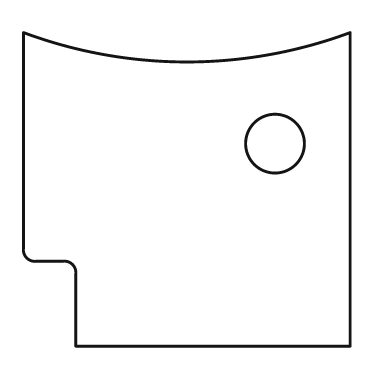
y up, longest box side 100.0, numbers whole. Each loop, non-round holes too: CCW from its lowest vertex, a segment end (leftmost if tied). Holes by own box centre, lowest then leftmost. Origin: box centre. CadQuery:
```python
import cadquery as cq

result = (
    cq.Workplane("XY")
    .moveTo(-34.0, -48.0)
    .lineTo(50.0, -48.0)
    .lineTo(50.0, 48.0)
    .threePointArc((0.0, 39.0), (-50.0, 48.0))
    .lineTo(-50.0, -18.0)
    .threePointArc((-49.0, -21.0), (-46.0, -22.0))
    .lineTo(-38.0, -22.0)
    .threePointArc((-35.0, -23.0), (-34.0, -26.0))
    .close()
    .moveTo(27.0, 14.0)
    .circle(9.0)
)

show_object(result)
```